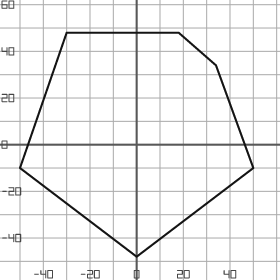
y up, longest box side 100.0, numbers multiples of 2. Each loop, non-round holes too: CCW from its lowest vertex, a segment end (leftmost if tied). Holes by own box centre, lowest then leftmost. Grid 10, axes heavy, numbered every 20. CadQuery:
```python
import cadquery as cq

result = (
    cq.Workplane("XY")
    .moveTo(0.0, -48.0)
    .lineTo(50.0, -10.0)
    .lineTo(34.0, 34.0)
    .lineTo(18.0, 48.0)
    .lineTo(-30.0, 48.0)
    .lineTo(-50.0, -10.0)
    .close()
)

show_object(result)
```